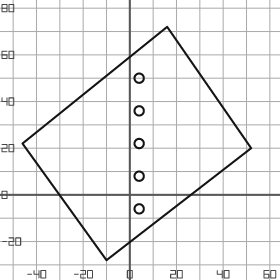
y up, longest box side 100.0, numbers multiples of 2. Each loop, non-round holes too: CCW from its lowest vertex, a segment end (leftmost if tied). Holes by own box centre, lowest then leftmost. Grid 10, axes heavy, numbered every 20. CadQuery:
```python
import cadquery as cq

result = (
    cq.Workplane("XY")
    .moveTo(-10.0, -28.0)
    .lineTo(52.0, 20.0)
    .lineTo(16.0, 72.0)
    .lineTo(-46.0, 22.0)
    .close()
    .moveTo(4.0, -6.0)
    .circle(2.0)
    .moveTo(4.0, 8.0)
    .circle(2.0)
    .moveTo(4.0, 22.0)
    .circle(2.0)
    .moveTo(4.0, 36.0)
    .circle(2.0)
    .moveTo(4.0, 50.0)
    .circle(2.0)
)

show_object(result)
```